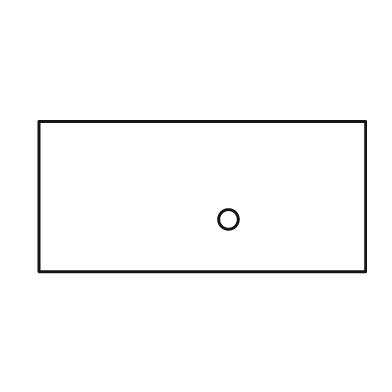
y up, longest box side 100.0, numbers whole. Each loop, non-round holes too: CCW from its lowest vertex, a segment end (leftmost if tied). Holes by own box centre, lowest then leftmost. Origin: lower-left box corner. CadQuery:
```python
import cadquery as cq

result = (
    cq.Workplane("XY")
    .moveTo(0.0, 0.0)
    .lineTo(100.0, 0.0)
    .lineTo(100.0, 46.0)
    .lineTo(0.0, 46.0)
    .close()
    .moveTo(58.0, 16.0)
    .circle(3.0)
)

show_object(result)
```